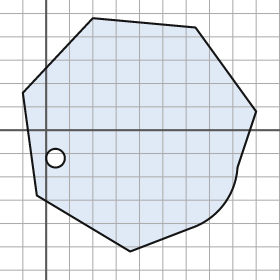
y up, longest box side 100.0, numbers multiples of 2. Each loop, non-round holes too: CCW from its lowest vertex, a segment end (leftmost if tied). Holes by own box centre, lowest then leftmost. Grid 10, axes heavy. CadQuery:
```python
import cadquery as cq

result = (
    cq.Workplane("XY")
    .moveTo(36.0, -52.0)
    .lineTo(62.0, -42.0)
    .threePointArc((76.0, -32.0), (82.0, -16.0))
    .lineTo(90.0, 8.0)
    .lineTo(64.0, 44.0)
    .lineTo(20.0, 48.0)
    .lineTo(-10.0, 16.0)
    .lineTo(-4.0, -28.0)
    .close()
    .moveTo(4.0, -12.0)
    .circle(4.0)
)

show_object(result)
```